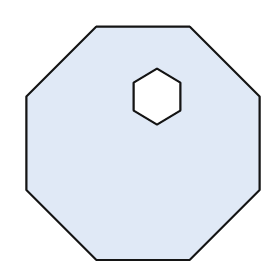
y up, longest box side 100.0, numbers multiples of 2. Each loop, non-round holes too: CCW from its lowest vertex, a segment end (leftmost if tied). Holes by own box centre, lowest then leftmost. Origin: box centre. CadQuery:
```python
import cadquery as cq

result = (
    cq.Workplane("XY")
    .moveTo(-20.0, -50.0)
    .lineTo(20.0, -50.0)
    .lineTo(50.0, -20.0)
    .lineTo(50.0, 20.0)
    .lineTo(20.0, 50.0)
    .lineTo(-20.0, 50.0)
    .lineTo(-50.0, 20.0)
    .lineTo(-50.0, -20.0)
    .close()
    .moveTo(6.0, 8.0)
    .lineTo(16.0, 14.0)
    .lineTo(16.0, 26.0)
    .lineTo(6.0, 32.0)
    .lineTo(-4.0, 26.0)
    .lineTo(-4.0, 14.0)
    .close()
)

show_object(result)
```